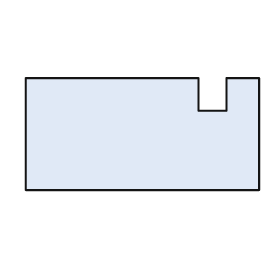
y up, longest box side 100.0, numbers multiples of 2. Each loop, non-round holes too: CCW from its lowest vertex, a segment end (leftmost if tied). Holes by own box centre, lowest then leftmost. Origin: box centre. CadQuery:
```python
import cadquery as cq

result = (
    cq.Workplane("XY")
    .moveTo(-50.0, -24.0)
    .lineTo(50.0, -24.0)
    .lineTo(50.0, 24.0)
    .lineTo(36.0, 24.0)
    .lineTo(36.0, 10.0)
    .lineTo(24.0, 10.0)
    .lineTo(24.0, 24.0)
    .lineTo(-50.0, 24.0)
    .close()
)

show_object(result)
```